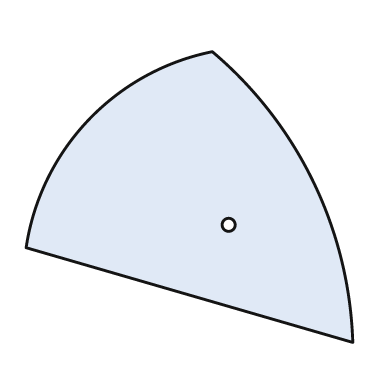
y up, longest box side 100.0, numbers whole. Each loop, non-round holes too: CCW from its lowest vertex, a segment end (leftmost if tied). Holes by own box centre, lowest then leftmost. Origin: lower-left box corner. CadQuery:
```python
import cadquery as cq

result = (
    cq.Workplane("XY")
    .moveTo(100.0, 0.0)
    .threePointArc((88.0, 49.0), (57.0, 89.0))
    .threePointArc((19.0, 68.0), (0.0, 29.0))
    .close()
    .moveTo(62.0, 36.0)
    .circle(2.0)
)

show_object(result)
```